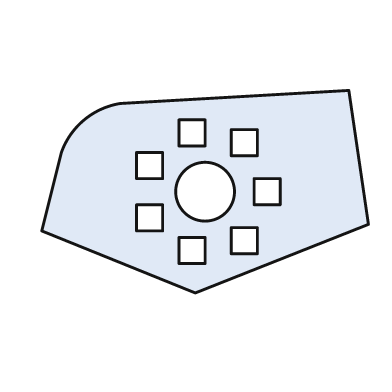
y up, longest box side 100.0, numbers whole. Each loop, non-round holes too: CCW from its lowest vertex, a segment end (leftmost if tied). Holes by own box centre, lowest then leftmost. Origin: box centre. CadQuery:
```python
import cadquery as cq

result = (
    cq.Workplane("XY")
    .moveTo(-3.0, -31.0)
    .lineTo(50.0, -10.0)
    .lineTo(44.0, 31.0)
    .lineTo(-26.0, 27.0)
    .threePointArc((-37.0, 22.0), (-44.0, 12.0))
    .lineTo(-50.0, -12.0)
    .close()
    .moveTo(-8.0, -22.0)
    .lineTo(0.0, -22.0)
    .lineTo(0.0, -14.0)
    .lineTo(-8.0, -14.0)
    .close()
    .moveTo(8.0, -19.0)
    .lineTo(16.0, -19.0)
    .lineTo(16.0, -11.0)
    .lineTo(8.0, -11.0)
    .close()
    .moveTo(-21.0, -12.0)
    .lineTo(-13.0, -12.0)
    .lineTo(-13.0, -4.0)
    .lineTo(-21.0, -4.0)
    .close()
    .moveTo(0.0, 0.0)
    .circle(9.0)
    .moveTo(15.0, -4.0)
    .lineTo(23.0, -4.0)
    .lineTo(23.0, 4.0)
    .lineTo(15.0, 4.0)
    .close()
    .moveTo(-21.0, 4.0)
    .lineTo(-13.0, 4.0)
    .lineTo(-13.0, 12.0)
    .lineTo(-21.0, 12.0)
    .close()
    .moveTo(8.0, 11.0)
    .lineTo(16.0, 11.0)
    .lineTo(16.0, 19.0)
    .lineTo(8.0, 19.0)
    .close()
    .moveTo(-8.0, 14.0)
    .lineTo(0.0, 14.0)
    .lineTo(0.0, 22.0)
    .lineTo(-8.0, 22.0)
    .close()
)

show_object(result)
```